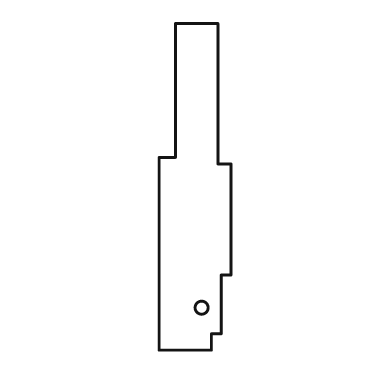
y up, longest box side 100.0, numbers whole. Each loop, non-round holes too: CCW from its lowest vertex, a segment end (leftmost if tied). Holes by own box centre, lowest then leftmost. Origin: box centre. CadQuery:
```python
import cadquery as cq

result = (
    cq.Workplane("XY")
    .moveTo(-11.0, -50.0)
    .lineTo(5.0, -50.0)
    .lineTo(5.0, -45.0)
    .lineTo(8.0, -45.0)
    .lineTo(8.0, -27.0)
    .lineTo(11.0, -27.0)
    .lineTo(11.0, 7.0)
    .lineTo(7.0, 7.0)
    .lineTo(7.0, 50.0)
    .lineTo(-6.0, 50.0)
    .lineTo(-6.0, 9.0)
    .lineTo(-11.0, 9.0)
    .close()
    .moveTo(2.0, -37.0)
    .circle(2.0)
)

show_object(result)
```